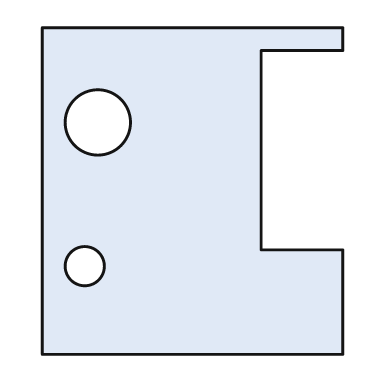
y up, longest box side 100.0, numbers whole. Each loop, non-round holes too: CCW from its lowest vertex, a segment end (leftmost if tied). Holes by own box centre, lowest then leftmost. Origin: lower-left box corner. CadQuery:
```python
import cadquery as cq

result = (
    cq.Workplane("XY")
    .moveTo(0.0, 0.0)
    .lineTo(92.0, 0.0)
    .lineTo(92.0, 32.0)
    .lineTo(67.0, 32.0)
    .lineTo(67.0, 93.0)
    .lineTo(92.0, 93.0)
    .lineTo(92.0, 100.0)
    .lineTo(0.0, 100.0)
    .close()
    .moveTo(13.0, 27.0)
    .circle(6.0)
    .moveTo(17.0, 71.0)
    .circle(10.0)
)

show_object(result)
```